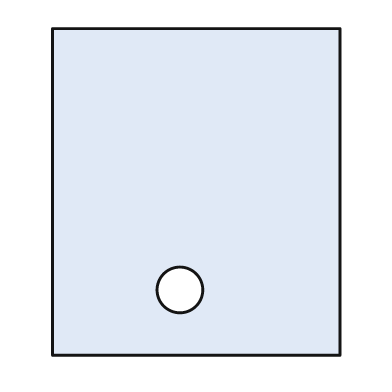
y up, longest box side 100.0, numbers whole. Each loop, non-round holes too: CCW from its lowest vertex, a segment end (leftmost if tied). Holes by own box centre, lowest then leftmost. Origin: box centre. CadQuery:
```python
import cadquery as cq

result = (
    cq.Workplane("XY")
    .moveTo(-44.0, -50.0)
    .lineTo(44.0, -50.0)
    .lineTo(44.0, 50.0)
    .lineTo(-44.0, 50.0)
    .close()
    .moveTo(-5.0, -30.0)
    .circle(7.0)
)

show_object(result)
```